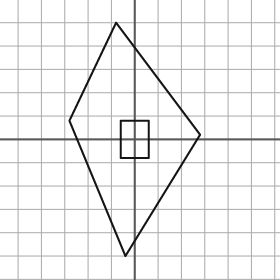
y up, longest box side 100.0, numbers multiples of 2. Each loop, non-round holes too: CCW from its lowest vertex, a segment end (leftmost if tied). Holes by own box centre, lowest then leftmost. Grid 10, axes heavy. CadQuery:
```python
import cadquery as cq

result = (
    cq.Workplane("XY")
    .moveTo(-4.0, -50.0)
    .lineTo(28.0, 2.0)
    .lineTo(-8.0, 50.0)
    .lineTo(-28.0, 8.0)
    .close()
    .moveTo(-6.0, -8.0)
    .lineTo(6.0, -8.0)
    .lineTo(6.0, 8.0)
    .lineTo(-6.0, 8.0)
    .close()
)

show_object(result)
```